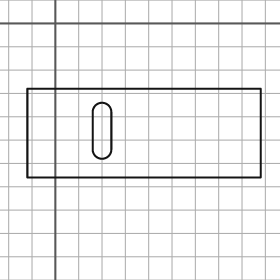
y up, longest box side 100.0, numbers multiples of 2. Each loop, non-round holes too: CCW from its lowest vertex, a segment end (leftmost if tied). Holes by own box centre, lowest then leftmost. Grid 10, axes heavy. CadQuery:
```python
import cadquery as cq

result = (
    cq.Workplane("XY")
    .moveTo(-12.0, -66.0)
    .lineTo(88.0, -66.0)
    .lineTo(88.0, -28.0)
    .lineTo(-12.0, -28.0)
    .close()
    .moveTo(16.0, -54.0)
    .threePointArc((20.0, -58.0), (24.0, -54.0))
    .lineTo(24.0, -38.0)
    .threePointArc((20.0, -34.0), (16.0, -38.0))
    .close()
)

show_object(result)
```